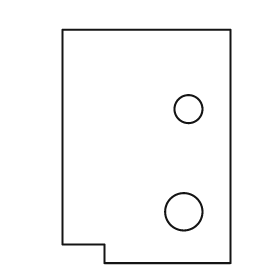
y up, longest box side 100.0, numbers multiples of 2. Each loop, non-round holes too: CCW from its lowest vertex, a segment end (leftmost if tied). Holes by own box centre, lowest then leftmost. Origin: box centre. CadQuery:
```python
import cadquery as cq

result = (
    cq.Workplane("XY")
    .moveTo(-18.0, -50.0)
    .lineTo(36.0, -50.0)
    .lineTo(36.0, 50.0)
    .lineTo(-36.0, 50.0)
    .lineTo(-36.0, -42.0)
    .lineTo(-18.0, -42.0)
    .close()
    .moveTo(16.0, -28.0)
    .circle(8.0)
    .moveTo(18.0, 16.0)
    .circle(6.0)
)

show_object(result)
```